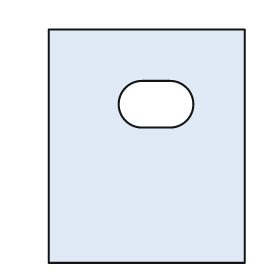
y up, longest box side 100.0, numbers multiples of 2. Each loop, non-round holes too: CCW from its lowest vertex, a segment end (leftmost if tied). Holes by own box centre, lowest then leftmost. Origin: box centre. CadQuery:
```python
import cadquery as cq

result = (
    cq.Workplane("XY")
    .moveTo(-42.0, -50.0)
    .lineTo(42.0, -50.0)
    .lineTo(42.0, 50.0)
    .lineTo(-42.0, 50.0)
    .close()
    .moveTo(-2.0, 8.0)
    .lineTo(10.0, 8.0)
    .threePointArc((20.0, 18.0), (10.0, 28.0))
    .lineTo(-2.0, 28.0)
    .threePointArc((-12.0, 18.0), (-2.0, 8.0))
    .close()
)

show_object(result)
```